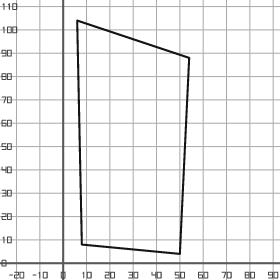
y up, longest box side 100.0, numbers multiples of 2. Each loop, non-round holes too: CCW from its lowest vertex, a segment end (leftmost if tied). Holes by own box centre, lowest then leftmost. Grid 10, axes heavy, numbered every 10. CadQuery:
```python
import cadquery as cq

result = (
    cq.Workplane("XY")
    .moveTo(50.0, 4.0)
    .lineTo(54.0, 88.0)
    .lineTo(6.0, 104.0)
    .lineTo(8.0, 8.0)
    .close()
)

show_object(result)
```